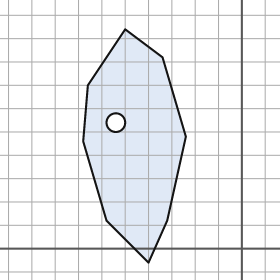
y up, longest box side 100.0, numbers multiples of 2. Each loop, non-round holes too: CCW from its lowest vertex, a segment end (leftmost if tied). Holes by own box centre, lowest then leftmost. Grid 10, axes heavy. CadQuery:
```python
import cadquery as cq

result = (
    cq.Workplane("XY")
    .moveTo(-40.0, -6.0)
    .lineTo(-32.0, 12.0)
    .lineTo(-24.0, 48.0)
    .lineTo(-34.0, 82.0)
    .lineTo(-50.0, 94.0)
    .lineTo(-66.0, 70.0)
    .lineTo(-68.0, 46.0)
    .lineTo(-58.0, 12.0)
    .close()
    .moveTo(-54.0, 54.0)
    .circle(4.0)
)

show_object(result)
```